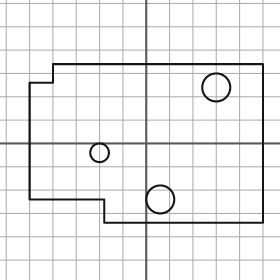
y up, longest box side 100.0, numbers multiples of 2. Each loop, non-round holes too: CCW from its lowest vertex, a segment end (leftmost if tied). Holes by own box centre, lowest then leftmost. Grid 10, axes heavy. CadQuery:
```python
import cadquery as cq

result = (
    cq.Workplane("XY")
    .moveTo(-18.0, -34.0)
    .lineTo(50.0, -34.0)
    .lineTo(50.0, 34.0)
    .lineTo(-40.0, 34.0)
    .lineTo(-40.0, 26.0)
    .lineTo(-50.0, 26.0)
    .lineTo(-50.0, -24.0)
    .lineTo(-18.0, -24.0)
    .close()
    .moveTo(6.0, -24.0)
    .circle(6.0)
    .moveTo(-20.0, -4.0)
    .circle(4.0)
    .moveTo(30.0, 24.0)
    .circle(6.0)
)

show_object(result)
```